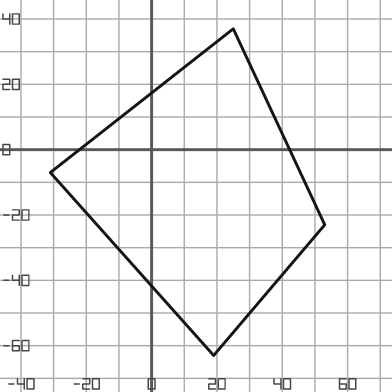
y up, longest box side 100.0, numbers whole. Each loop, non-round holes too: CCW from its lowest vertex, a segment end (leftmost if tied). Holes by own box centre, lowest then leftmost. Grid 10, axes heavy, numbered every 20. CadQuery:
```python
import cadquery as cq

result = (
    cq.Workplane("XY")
    .moveTo(19.0, -63.0)
    .lineTo(53.0, -23.0)
    .lineTo(25.0, 37.0)
    .lineTo(-31.0, -7.0)
    .close()
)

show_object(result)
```